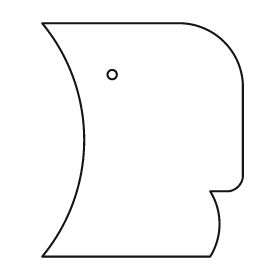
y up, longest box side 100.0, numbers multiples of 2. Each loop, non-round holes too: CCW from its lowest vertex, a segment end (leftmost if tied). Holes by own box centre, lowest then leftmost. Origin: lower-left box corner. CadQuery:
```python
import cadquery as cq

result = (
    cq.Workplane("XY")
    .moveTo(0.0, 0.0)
    .lineTo(72.0, 0.0)
    .threePointArc((76.0, 14.0), (72.0, 28.0))
    .lineTo(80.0, 28.0)
    .threePointArc((84.0, 30.0), (86.0, 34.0))
    .lineTo(86.0, 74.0)
    .threePointArc((78.0, 92.0), (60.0, 100.0))
    .lineTo(0.0, 100.0)
    .threePointArc((18.0, 50.0), (0.0, 0.0))
    .close()
    .moveTo(30.0, 78.0)
    .circle(2.0)
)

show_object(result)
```